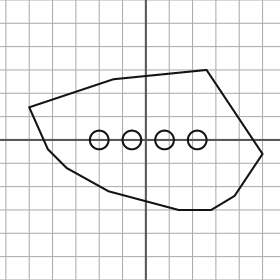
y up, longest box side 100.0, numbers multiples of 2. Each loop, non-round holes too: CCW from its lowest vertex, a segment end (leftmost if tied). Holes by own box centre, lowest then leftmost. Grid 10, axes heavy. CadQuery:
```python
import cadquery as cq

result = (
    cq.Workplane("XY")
    .moveTo(14.0, -30.0)
    .lineTo(28.0, -30.0)
    .lineTo(38.0, -24.0)
    .lineTo(50.0, -6.0)
    .lineTo(26.0, 30.0)
    .lineTo(-14.0, 26.0)
    .lineTo(-50.0, 14.0)
    .lineTo(-42.0, -4.0)
    .lineTo(-34.0, -12.0)
    .lineTo(-16.0, -22.0)
    .close()
    .moveTo(-20.0, 0.0)
    .circle(4.0)
    .moveTo(-6.0, 0.0)
    .circle(4.0)
    .moveTo(8.0, 0.0)
    .circle(4.0)
    .moveTo(22.0, 0.0)
    .circle(4.0)
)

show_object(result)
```